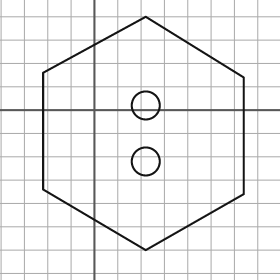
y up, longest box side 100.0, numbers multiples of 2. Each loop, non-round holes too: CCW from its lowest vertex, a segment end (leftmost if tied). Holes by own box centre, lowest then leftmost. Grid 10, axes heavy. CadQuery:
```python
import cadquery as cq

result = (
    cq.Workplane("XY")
    .moveTo(22.0, -60.0)
    .lineTo(64.0, -36.0)
    .lineTo(64.0, 14.0)
    .lineTo(22.0, 40.0)
    .lineTo(-22.0, 16.0)
    .lineTo(-22.0, -34.0)
    .close()
    .moveTo(22.0, -22.0)
    .circle(6.0)
    .moveTo(22.0, 2.0)
    .circle(6.0)
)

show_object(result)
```